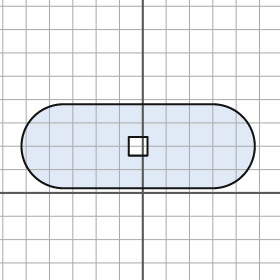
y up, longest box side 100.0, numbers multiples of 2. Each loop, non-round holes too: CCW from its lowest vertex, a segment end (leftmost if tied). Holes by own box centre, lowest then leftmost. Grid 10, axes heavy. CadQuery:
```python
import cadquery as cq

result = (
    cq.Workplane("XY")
    .moveTo(-34.0, 2.0)
    .lineTo(30.0, 2.0)
    .threePointArc((48.0, 20.0), (30.0, 38.0))
    .lineTo(-34.0, 38.0)
    .threePointArc((-52.0, 20.0), (-34.0, 2.0))
    .close()
    .moveTo(-6.0, 16.0)
    .lineTo(2.0, 16.0)
    .lineTo(2.0, 24.0)
    .lineTo(-6.0, 24.0)
    .close()
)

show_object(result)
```